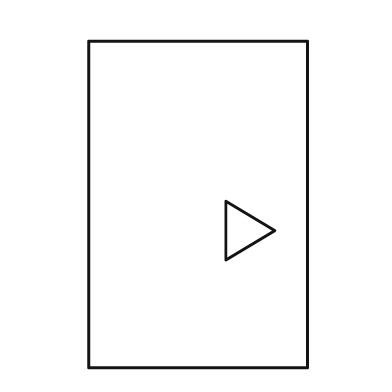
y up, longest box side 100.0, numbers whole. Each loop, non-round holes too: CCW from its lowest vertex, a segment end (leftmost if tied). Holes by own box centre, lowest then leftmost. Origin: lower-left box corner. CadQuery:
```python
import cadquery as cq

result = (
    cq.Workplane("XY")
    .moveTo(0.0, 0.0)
    .lineTo(67.0, 0.0)
    .lineTo(67.0, 100.0)
    .lineTo(0.0, 100.0)
    .close()
    .moveTo(42.0, 33.0)
    .lineTo(57.0, 42.0)
    .lineTo(42.0, 51.0)
    .close()
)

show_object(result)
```